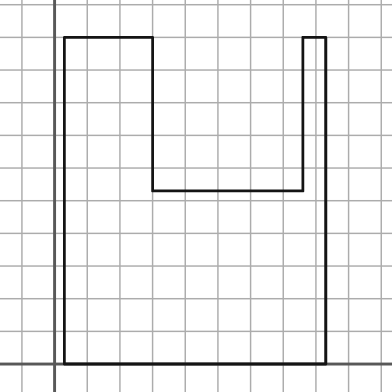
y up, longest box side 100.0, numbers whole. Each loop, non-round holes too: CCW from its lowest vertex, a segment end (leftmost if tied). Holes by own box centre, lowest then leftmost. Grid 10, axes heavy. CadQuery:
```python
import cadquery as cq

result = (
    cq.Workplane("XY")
    .moveTo(3.0, 0.0)
    .lineTo(83.0, 0.0)
    .lineTo(83.0, 100.0)
    .lineTo(76.0, 100.0)
    .lineTo(76.0, 53.0)
    .lineTo(30.0, 53.0)
    .lineTo(30.0, 100.0)
    .lineTo(3.0, 100.0)
    .close()
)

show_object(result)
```